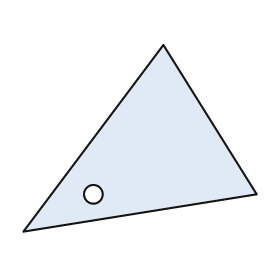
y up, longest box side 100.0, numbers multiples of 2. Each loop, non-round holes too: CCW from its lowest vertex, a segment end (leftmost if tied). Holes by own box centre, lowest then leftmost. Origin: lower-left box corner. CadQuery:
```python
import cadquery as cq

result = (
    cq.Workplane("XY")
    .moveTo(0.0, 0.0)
    .lineTo(100.0, 16.0)
    .lineTo(60.0, 80.0)
    .close()
    .moveTo(30.0, 16.0)
    .circle(4.0)
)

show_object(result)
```